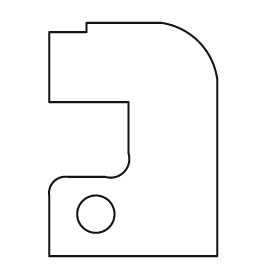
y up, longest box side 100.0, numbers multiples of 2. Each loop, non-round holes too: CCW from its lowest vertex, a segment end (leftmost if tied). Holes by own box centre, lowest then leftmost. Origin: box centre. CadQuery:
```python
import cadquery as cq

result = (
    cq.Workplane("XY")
    .moveTo(-36.0, -50.0)
    .lineTo(36.0, -50.0)
    .lineTo(36.0, 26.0)
    .threePointArc((28.0, 42.0), (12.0, 50.0))
    .lineTo(-20.0, 50.0)
    .lineTo(-20.0, 46.0)
    .lineTo(-36.0, 46.0)
    .lineTo(-36.0, 16.0)
    .lineTo(-2.0, 16.0)
    .lineTo(-2.0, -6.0)
    .threePointArc((-4.0, -14.0), (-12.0, -16.0))
    .lineTo(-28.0, -16.0)
    .threePointArc((-34.0, -18.0), (-36.0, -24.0))
    .close()
    .moveTo(-16.0, -32.0)
    .circle(8.0)
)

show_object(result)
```